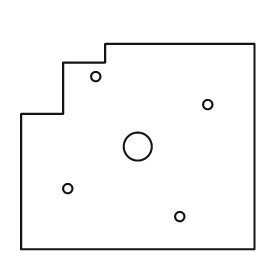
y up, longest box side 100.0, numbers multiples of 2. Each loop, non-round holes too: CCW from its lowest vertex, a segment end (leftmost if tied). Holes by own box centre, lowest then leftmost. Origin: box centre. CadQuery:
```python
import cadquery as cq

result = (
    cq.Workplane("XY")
    .moveTo(-50.0, -44.0)
    .lineTo(50.0, -44.0)
    .lineTo(50.0, 44.0)
    .lineTo(-14.0, 44.0)
    .lineTo(-14.0, 36.0)
    .lineTo(-32.0, 36.0)
    .lineTo(-32.0, 14.0)
    .lineTo(-50.0, 14.0)
    .close()
    .moveTo(18.0, -30.0)
    .circle(2.0)
    .moveTo(-30.0, -18.0)
    .circle(2.0)
    .moveTo(0.0, 0.0)
    .circle(6.0)
    .moveTo(30.0, 18.0)
    .circle(2.0)
    .moveTo(-18.0, 30.0)
    .circle(2.0)
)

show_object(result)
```